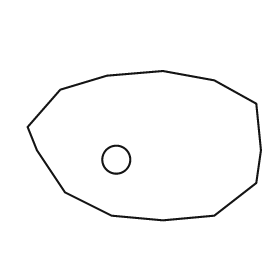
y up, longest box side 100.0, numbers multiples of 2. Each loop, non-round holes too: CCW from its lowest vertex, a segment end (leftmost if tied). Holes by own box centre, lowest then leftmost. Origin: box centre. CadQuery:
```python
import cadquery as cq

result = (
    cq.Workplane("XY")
    .moveTo(8.0, -32.0)
    .lineTo(30.0, -30.0)
    .lineTo(48.0, -16.0)
    .lineTo(50.0, -2.0)
    .lineTo(48.0, 18.0)
    .lineTo(30.0, 28.0)
    .lineTo(8.0, 32.0)
    .lineTo(-16.0, 30.0)
    .lineTo(-36.0, 24.0)
    .lineTo(-50.0, 8.0)
    .lineTo(-46.0, -2.0)
    .lineTo(-34.0, -20.0)
    .lineTo(-14.0, -30.0)
    .close()
    .moveTo(-12.0, -6.0)
    .circle(6.0)
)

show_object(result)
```